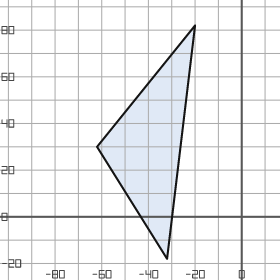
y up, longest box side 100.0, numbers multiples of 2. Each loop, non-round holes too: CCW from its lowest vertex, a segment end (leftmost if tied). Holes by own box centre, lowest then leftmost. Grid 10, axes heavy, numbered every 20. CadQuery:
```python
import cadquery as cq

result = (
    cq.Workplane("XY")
    .moveTo(-32.0, -18.0)
    .lineTo(-20.0, 82.0)
    .lineTo(-62.0, 30.0)
    .close()
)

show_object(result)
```